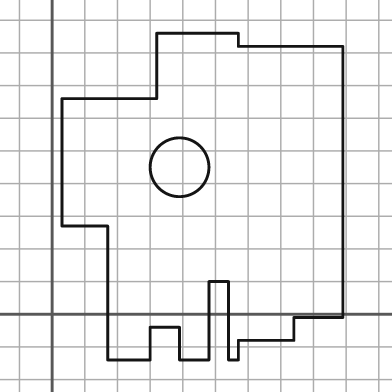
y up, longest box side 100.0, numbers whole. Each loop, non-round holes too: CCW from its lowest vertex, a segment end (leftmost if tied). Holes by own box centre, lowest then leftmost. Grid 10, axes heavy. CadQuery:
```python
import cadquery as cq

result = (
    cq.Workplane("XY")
    .moveTo(17.0, -14.0)
    .lineTo(30.0, -14.0)
    .lineTo(30.0, -4.0)
    .lineTo(39.0, -4.0)
    .lineTo(39.0, -14.0)
    .lineTo(48.0, -14.0)
    .lineTo(48.0, 10.0)
    .lineTo(54.0, 10.0)
    .lineTo(54.0, -14.0)
    .lineTo(57.0, -14.0)
    .lineTo(57.0, -8.0)
    .lineTo(74.0, -8.0)
    .lineTo(74.0, -1.0)
    .lineTo(89.0, -1.0)
    .lineTo(89.0, 82.0)
    .lineTo(57.0, 82.0)
    .lineTo(57.0, 86.0)
    .lineTo(32.0, 86.0)
    .lineTo(32.0, 66.0)
    .lineTo(3.0, 66.0)
    .lineTo(3.0, 27.0)
    .lineTo(17.0, 27.0)
    .close()
    .moveTo(39.0, 45.0)
    .circle(9.0)
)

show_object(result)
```